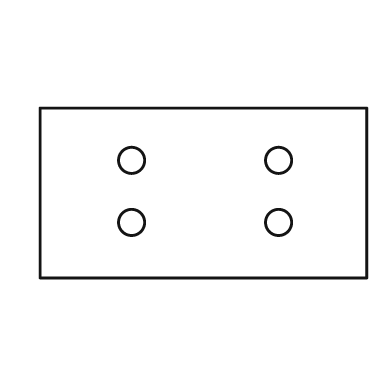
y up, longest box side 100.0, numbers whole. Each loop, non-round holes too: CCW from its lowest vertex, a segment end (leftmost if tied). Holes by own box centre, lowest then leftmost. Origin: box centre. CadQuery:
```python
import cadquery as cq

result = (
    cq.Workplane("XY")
    .moveTo(-50.0, -26.0)
    .lineTo(50.0, -26.0)
    .lineTo(50.0, 26.0)
    .lineTo(-50.0, 26.0)
    .close()
    .moveTo(-22.0, -9.0)
    .circle(4.0)
    .moveTo(23.0, -9.0)
    .circle(4.0)
    .moveTo(-22.0, 10.0)
    .circle(4.0)
    .moveTo(23.0, 10.0)
    .circle(4.0)
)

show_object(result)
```